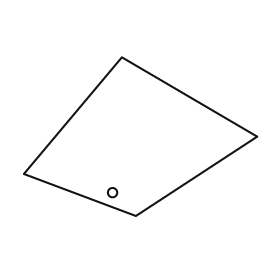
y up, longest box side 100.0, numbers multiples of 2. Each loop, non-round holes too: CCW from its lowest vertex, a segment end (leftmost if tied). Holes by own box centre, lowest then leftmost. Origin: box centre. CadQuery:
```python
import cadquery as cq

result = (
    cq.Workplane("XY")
    .moveTo(-2.0, -34.0)
    .lineTo(50.0, 0.0)
    .lineTo(-8.0, 34.0)
    .lineTo(-50.0, -16.0)
    .close()
    .moveTo(-12.0, -24.0)
    .circle(2.0)
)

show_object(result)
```